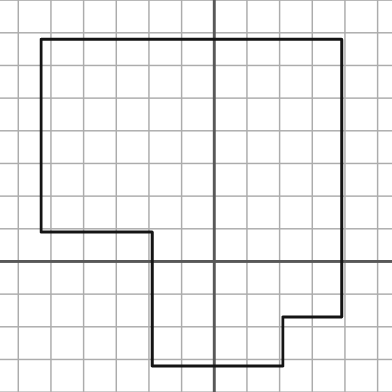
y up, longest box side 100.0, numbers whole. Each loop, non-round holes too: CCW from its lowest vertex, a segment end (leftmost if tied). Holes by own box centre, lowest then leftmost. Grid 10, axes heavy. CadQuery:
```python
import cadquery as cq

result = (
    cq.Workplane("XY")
    .moveTo(-19.0, -32.0)
    .lineTo(21.0, -32.0)
    .lineTo(21.0, -17.0)
    .lineTo(39.0, -17.0)
    .lineTo(39.0, 68.0)
    .lineTo(-53.0, 68.0)
    .lineTo(-53.0, 9.0)
    .lineTo(-19.0, 9.0)
    .close()
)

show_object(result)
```